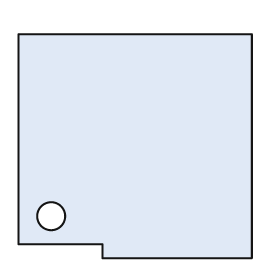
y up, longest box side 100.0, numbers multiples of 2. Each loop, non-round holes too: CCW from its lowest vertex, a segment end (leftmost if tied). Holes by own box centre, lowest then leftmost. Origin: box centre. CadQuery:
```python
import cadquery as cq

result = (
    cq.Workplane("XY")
    .moveTo(-14.0, -48.0)
    .lineTo(50.0, -48.0)
    .lineTo(50.0, 48.0)
    .lineTo(-50.0, 48.0)
    .lineTo(-50.0, -42.0)
    .lineTo(-14.0, -42.0)
    .close()
    .moveTo(-36.0, -30.0)
    .circle(6.0)
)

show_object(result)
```